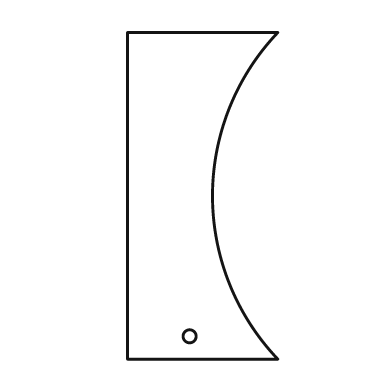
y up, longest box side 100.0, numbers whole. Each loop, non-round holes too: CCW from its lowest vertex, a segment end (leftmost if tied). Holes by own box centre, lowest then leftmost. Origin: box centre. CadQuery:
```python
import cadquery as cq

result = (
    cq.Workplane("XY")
    .moveTo(-23.0, -50.0)
    .lineTo(23.0, -50.0)
    .threePointArc((3.0, 0.0), (23.0, 50.0))
    .lineTo(-23.0, 50.0)
    .close()
    .moveTo(-4.0, -43.0)
    .circle(2.0)
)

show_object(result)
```